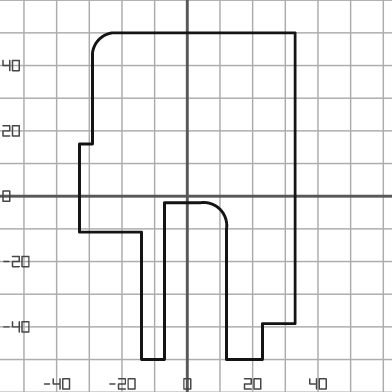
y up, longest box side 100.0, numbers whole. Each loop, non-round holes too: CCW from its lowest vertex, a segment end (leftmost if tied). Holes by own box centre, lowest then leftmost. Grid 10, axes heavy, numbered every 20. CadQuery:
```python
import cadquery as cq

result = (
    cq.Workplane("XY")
    .moveTo(-14.0, -50.0)
    .lineTo(-7.0, -50.0)
    .lineTo(-7.0, -2.0)
    .lineTo(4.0, -2.0)
    .threePointArc((10.0, -4.0), (12.0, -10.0))
    .lineTo(12.0, -50.0)
    .lineTo(23.0, -50.0)
    .lineTo(23.0, -39.0)
    .lineTo(33.0, -39.0)
    .lineTo(33.0, 50.0)
    .lineTo(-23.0, 50.0)
    .threePointArc((-27.0, 48.0), (-29.0, 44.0))
    .lineTo(-29.0, 16.0)
    .lineTo(-33.0, 16.0)
    .lineTo(-33.0, -11.0)
    .lineTo(-14.0, -11.0)
    .close()
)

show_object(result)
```